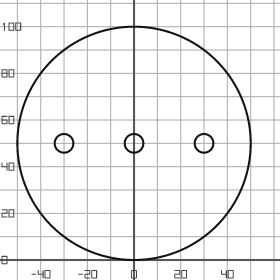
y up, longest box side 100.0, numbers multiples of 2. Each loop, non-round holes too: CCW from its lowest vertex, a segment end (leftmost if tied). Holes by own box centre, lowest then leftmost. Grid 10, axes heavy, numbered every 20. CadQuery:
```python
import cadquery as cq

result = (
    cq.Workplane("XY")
    .moveTo(0.0, 50.0)
    .circle(50.0)
    .moveTo(-30.0, 50.0)
    .circle(4.0)
    .moveTo(0.0, 50.0)
    .circle(4.0)
    .moveTo(30.0, 50.0)
    .circle(4.0)
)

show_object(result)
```